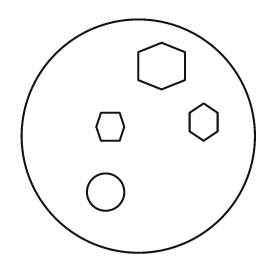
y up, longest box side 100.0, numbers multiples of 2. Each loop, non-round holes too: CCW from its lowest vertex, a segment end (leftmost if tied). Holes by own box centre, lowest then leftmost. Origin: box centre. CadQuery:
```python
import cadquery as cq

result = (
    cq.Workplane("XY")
    .moveTo(0.0, 0.0)
    .circle(50.0)
    .moveTo(-14.0, -24.0)
    .circle(8.0)
    .moveTo(-16.0, -2.0)
    .lineTo(-8.0, -2.0)
    .lineTo(-6.0, 4.0)
    .lineTo(-8.0, 10.0)
    .lineTo(-16.0, 10.0)
    .lineTo(-18.0, 4.0)
    .close()
    .moveTo(28.0, -2.0)
    .lineTo(34.0, 2.0)
    .lineTo(34.0, 10.0)
    .lineTo(28.0, 14.0)
    .lineTo(22.0, 10.0)
    .lineTo(22.0, 2.0)
    .close()
    .moveTo(10.0, 20.0)
    .lineTo(20.0, 24.0)
    .lineTo(20.0, 36.0)
    .lineTo(10.0, 40.0)
    .lineTo(0.0, 36.0)
    .lineTo(0.0, 24.0)
    .close()
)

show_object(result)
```